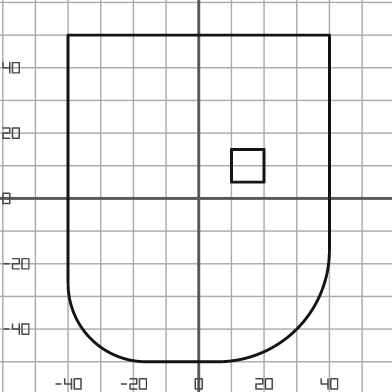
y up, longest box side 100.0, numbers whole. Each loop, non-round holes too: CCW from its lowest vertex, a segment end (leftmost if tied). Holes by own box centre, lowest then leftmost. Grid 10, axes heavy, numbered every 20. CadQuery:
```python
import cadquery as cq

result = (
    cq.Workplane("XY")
    .moveTo(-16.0, -50.0)
    .lineTo(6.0, -50.0)
    .threePointArc((30.0, -40.0), (40.0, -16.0))
    .lineTo(40.0, 50.0)
    .lineTo(-40.0, 50.0)
    .lineTo(-40.0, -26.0)
    .threePointArc((-33.0, -43.0), (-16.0, -50.0))
    .close()
    .moveTo(10.0, 5.0)
    .lineTo(20.0, 5.0)
    .lineTo(20.0, 15.0)
    .lineTo(10.0, 15.0)
    .close()
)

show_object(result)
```